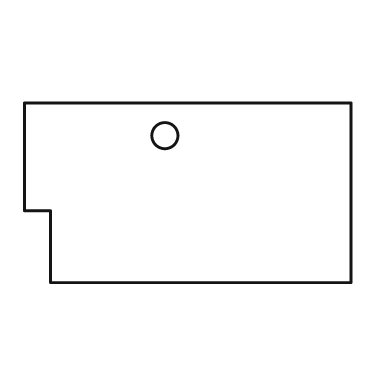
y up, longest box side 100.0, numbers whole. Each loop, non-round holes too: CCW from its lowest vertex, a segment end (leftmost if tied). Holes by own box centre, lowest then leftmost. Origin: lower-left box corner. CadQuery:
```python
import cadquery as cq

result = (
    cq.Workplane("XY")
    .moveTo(8.0, 0.0)
    .lineTo(100.0, 0.0)
    .lineTo(100.0, 55.0)
    .lineTo(0.0, 55.0)
    .lineTo(0.0, 22.0)
    .lineTo(8.0, 22.0)
    .close()
    .moveTo(43.0, 45.0)
    .circle(4.0)
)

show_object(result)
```